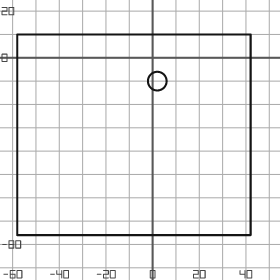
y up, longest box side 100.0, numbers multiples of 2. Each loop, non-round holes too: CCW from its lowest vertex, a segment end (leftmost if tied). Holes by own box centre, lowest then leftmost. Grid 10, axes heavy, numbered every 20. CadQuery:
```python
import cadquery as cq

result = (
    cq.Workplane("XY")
    .moveTo(-58.0, -76.0)
    .lineTo(42.0, -76.0)
    .lineTo(42.0, 10.0)
    .lineTo(-58.0, 10.0)
    .close()
    .moveTo(2.0, -10.0)
    .circle(4.0)
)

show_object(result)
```